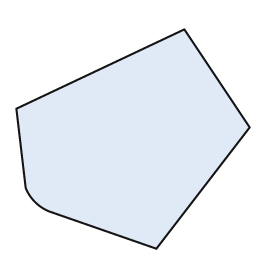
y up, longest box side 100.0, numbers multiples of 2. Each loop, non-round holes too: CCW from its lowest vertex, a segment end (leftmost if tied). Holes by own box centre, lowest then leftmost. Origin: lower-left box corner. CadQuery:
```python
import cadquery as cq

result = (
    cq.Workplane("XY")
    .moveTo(60.0, 0.0)
    .lineTo(100.0, 52.0)
    .lineTo(72.0, 94.0)
    .lineTo(0.0, 60.0)
    .lineTo(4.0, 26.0)
    .threePointArc((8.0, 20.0), (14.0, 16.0))
    .close()
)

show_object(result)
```